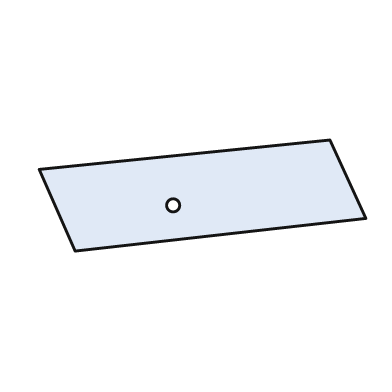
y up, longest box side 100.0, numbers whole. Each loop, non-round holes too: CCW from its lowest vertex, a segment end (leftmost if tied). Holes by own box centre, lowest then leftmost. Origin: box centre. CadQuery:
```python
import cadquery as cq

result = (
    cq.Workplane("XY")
    .moveTo(-39.0, -17.0)
    .lineTo(50.0, -7.0)
    .lineTo(39.0, 17.0)
    .lineTo(-50.0, 8.0)
    .close()
    .moveTo(-9.0, -3.0)
    .circle(2.0)
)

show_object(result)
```